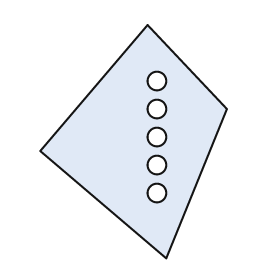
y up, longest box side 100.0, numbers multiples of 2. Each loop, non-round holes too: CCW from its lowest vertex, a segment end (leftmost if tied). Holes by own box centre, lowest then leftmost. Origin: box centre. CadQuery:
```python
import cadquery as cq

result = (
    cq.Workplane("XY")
    .moveTo(14.0, -50.0)
    .lineTo(40.0, 14.0)
    .lineTo(6.0, 50.0)
    .lineTo(-40.0, -4.0)
    .close()
    .moveTo(10.0, -22.0)
    .circle(4.0)
    .moveTo(10.0, -10.0)
    .circle(4.0)
    .moveTo(10.0, 2.0)
    .circle(4.0)
    .moveTo(10.0, 14.0)
    .circle(4.0)
    .moveTo(10.0, 26.0)
    .circle(4.0)
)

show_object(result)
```